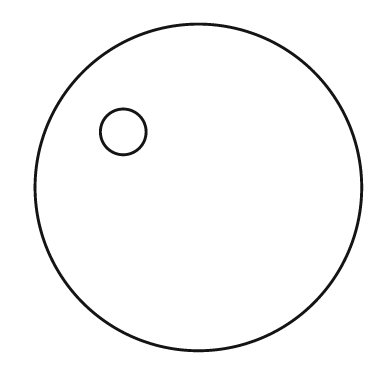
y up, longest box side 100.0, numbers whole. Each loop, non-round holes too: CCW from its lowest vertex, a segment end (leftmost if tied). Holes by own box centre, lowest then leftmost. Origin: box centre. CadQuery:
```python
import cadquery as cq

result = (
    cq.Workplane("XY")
    .moveTo(0.0, 0.0)
    .circle(50.0)
    .moveTo(-23.0, 17.0)
    .circle(7.0)
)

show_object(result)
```